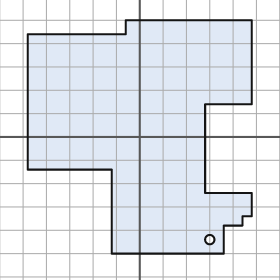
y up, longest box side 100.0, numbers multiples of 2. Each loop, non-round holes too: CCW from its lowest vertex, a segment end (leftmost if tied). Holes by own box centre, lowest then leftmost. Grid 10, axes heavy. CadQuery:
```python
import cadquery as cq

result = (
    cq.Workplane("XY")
    .moveTo(-12.0, -50.0)
    .lineTo(36.0, -50.0)
    .lineTo(36.0, -38.0)
    .lineTo(44.0, -38.0)
    .lineTo(44.0, -34.0)
    .lineTo(48.0, -34.0)
    .lineTo(48.0, -24.0)
    .lineTo(28.0, -24.0)
    .lineTo(28.0, 14.0)
    .lineTo(48.0, 14.0)
    .lineTo(48.0, 50.0)
    .lineTo(-6.0, 50.0)
    .lineTo(-6.0, 44.0)
    .lineTo(-48.0, 44.0)
    .lineTo(-48.0, -14.0)
    .lineTo(-12.0, -14.0)
    .close()
    .moveTo(30.0, -44.0)
    .circle(2.0)
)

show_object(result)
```